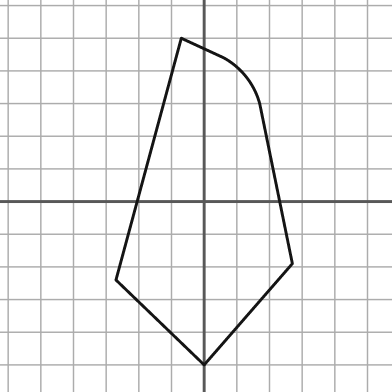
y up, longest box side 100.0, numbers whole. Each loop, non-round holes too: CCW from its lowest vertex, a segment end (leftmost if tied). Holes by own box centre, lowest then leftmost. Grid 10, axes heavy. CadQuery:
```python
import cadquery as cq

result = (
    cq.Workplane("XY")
    .moveTo(0.0, -50.0)
    .lineTo(27.0, -19.0)
    .lineTo(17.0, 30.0)
    .threePointArc((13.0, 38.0), (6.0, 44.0))
    .lineTo(-7.0, 50.0)
    .lineTo(-27.0, -24.0)
    .close()
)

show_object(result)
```